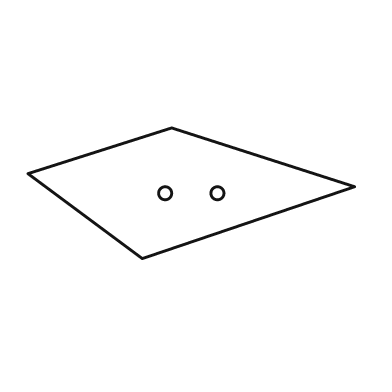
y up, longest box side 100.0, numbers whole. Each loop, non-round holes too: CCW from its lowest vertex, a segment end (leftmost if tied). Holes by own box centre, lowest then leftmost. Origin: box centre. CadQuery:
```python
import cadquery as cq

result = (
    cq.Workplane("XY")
    .moveTo(-15.0, -20.0)
    .lineTo(50.0, 2.0)
    .lineTo(-6.0, 20.0)
    .lineTo(-50.0, 6.0)
    .close()
    .moveTo(-8.0, 0.0)
    .circle(2.0)
    .moveTo(8.0, 0.0)
    .circle(2.0)
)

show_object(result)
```